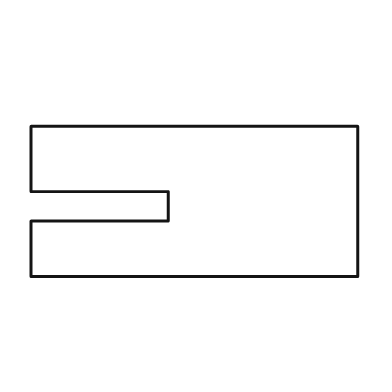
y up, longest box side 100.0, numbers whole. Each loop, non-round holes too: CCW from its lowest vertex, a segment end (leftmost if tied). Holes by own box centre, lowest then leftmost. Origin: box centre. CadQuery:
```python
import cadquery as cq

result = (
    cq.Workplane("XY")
    .moveTo(-50.0, -23.0)
    .lineTo(50.0, -23.0)
    .lineTo(50.0, 23.0)
    .lineTo(-50.0, 23.0)
    .lineTo(-50.0, 3.0)
    .lineTo(-8.0, 3.0)
    .lineTo(-8.0, -6.0)
    .lineTo(-50.0, -6.0)
    .close()
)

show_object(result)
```